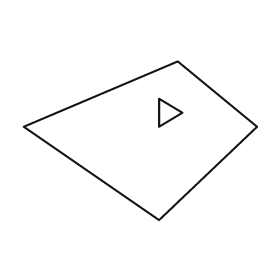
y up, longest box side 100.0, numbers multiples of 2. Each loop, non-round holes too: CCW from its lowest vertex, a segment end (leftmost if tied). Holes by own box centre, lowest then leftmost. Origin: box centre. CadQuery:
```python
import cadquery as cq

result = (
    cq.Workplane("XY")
    .moveTo(8.0, -34.0)
    .lineTo(50.0, 6.0)
    .lineTo(16.0, 34.0)
    .lineTo(-50.0, 6.0)
    .close()
    .moveTo(8.0, 6.0)
    .lineTo(18.0, 12.0)
    .lineTo(8.0, 18.0)
    .close()
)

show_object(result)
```